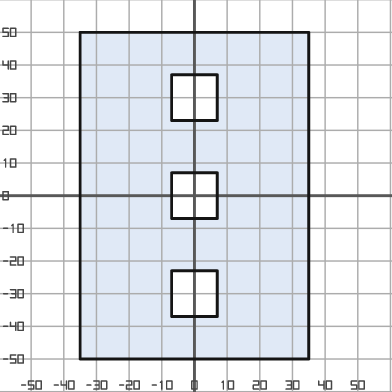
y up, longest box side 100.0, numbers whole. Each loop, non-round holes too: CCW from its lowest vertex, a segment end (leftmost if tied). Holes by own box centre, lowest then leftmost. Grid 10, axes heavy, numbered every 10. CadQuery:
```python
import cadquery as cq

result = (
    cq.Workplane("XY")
    .moveTo(-35.0, -50.0)
    .lineTo(35.0, -50.0)
    .lineTo(35.0, 50.0)
    .lineTo(-35.0, 50.0)
    .close()
    .moveTo(-7.0, -37.0)
    .lineTo(7.0, -37.0)
    .lineTo(7.0, -23.0)
    .lineTo(-7.0, -23.0)
    .close()
    .moveTo(-7.0, -7.0)
    .lineTo(7.0, -7.0)
    .lineTo(7.0, 7.0)
    .lineTo(-7.0, 7.0)
    .close()
    .moveTo(-7.0, 23.0)
    .lineTo(7.0, 23.0)
    .lineTo(7.0, 37.0)
    .lineTo(-7.0, 37.0)
    .close()
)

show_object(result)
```